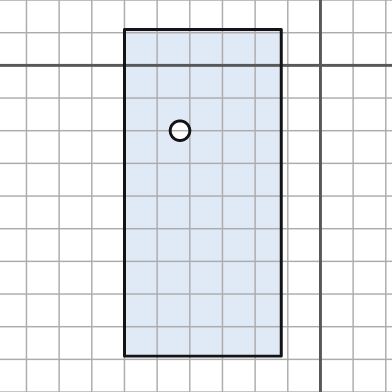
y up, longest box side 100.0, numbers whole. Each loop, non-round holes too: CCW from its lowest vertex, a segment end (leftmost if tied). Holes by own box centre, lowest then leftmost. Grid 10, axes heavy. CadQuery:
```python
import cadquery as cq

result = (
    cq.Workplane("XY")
    .moveTo(-60.0, -89.0)
    .lineTo(-12.0, -89.0)
    .lineTo(-12.0, 11.0)
    .lineTo(-60.0, 11.0)
    .close()
    .moveTo(-43.0, -20.0)
    .circle(3.0)
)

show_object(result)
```